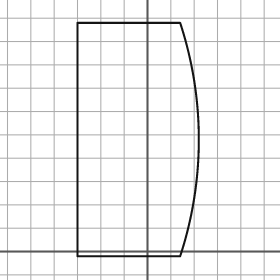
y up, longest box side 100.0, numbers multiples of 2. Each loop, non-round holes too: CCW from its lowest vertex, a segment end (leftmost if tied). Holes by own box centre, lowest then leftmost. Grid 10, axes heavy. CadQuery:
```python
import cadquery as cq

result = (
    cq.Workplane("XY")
    .moveTo(-30.0, -2.0)
    .lineTo(14.0, -2.0)
    .threePointArc((22.0, 48.0), (14.0, 98.0))
    .lineTo(-30.0, 98.0)
    .close()
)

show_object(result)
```